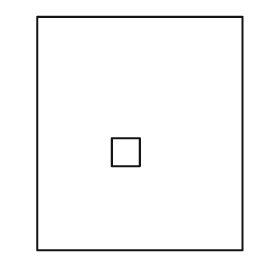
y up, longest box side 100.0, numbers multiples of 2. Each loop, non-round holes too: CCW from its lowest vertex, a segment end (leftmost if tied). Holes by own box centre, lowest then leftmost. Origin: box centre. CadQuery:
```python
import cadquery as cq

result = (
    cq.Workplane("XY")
    .moveTo(-44.0, -50.0)
    .lineTo(44.0, -50.0)
    .lineTo(44.0, 50.0)
    .lineTo(-44.0, 50.0)
    .close()
    .moveTo(-12.0, -14.0)
    .lineTo(0.0, -14.0)
    .lineTo(0.0, -2.0)
    .lineTo(-12.0, -2.0)
    .close()
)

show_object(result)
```